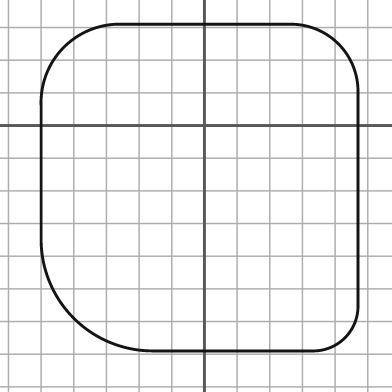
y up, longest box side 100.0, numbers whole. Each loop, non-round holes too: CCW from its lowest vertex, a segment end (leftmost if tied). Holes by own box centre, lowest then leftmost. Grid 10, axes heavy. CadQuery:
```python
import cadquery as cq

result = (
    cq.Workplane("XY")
    .moveTo(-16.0, -69.0)
    .lineTo(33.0, -69.0)
    .threePointArc((43.0, -65.0), (47.0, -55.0))
    .lineTo(47.0, 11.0)
    .threePointArc((41.0, 25.0), (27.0, 31.0))
    .lineTo(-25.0, 31.0)
    .threePointArc((-43.0, 24.0), (-50.0, 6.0))
    .lineTo(-50.0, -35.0)
    .threePointArc((-40.0, -59.0), (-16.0, -69.0))
    .close()
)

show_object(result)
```